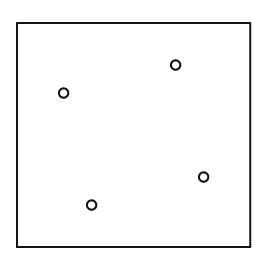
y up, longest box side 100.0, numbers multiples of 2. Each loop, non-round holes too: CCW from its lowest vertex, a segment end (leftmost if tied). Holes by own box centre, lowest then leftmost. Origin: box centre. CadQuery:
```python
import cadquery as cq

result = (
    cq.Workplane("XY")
    .moveTo(-50.0, -48.0)
    .lineTo(50.0, -48.0)
    .lineTo(50.0, 48.0)
    .lineTo(-50.0, 48.0)
    .close()
    .moveTo(-18.0, -30.0)
    .circle(2.0)
    .moveTo(30.0, -18.0)
    .circle(2.0)
    .moveTo(-30.0, 18.0)
    .circle(2.0)
    .moveTo(18.0, 30.0)
    .circle(2.0)
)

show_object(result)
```